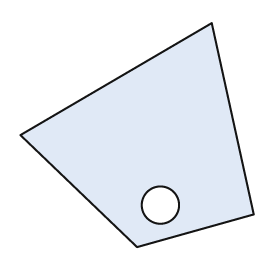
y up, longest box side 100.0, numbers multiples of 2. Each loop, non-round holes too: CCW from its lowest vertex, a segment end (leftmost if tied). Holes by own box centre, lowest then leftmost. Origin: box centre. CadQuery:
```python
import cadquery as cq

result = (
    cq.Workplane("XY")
    .moveTo(0.0, -48.0)
    .lineTo(50.0, -34.0)
    .lineTo(32.0, 48.0)
    .lineTo(-50.0, 0.0)
    .close()
    .moveTo(10.0, -30.0)
    .circle(8.0)
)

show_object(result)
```